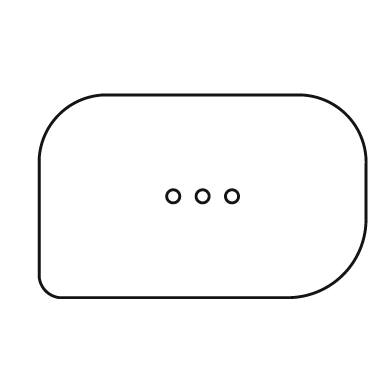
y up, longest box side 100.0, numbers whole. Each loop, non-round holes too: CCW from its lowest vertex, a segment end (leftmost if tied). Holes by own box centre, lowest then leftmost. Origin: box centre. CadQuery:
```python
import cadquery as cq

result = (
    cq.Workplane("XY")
    .moveTo(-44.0, -31.0)
    .lineTo(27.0, -31.0)
    .threePointArc((43.0, -24.0), (50.0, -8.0))
    .lineTo(50.0, 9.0)
    .threePointArc((44.0, 25.0), (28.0, 31.0))
    .lineTo(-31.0, 31.0)
    .threePointArc((-44.0, 25.0), (-50.0, 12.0))
    .lineTo(-50.0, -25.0)
    .threePointArc((-48.0, -29.0), (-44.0, -31.0))
    .close()
    .moveTo(-9.0, 0.0)
    .circle(2.0)
    .moveTo(0.0, 0.0)
    .circle(2.0)
    .moveTo(9.0, 0.0)
    .circle(2.0)
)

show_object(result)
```